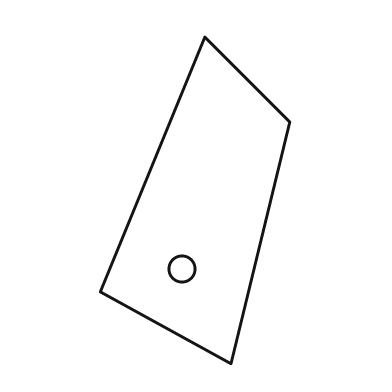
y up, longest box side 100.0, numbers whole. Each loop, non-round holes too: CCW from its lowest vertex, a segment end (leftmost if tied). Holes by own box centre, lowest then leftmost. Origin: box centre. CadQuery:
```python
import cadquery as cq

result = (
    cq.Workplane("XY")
    .moveTo(11.0, -50.0)
    .lineTo(29.0, 24.0)
    .lineTo(3.0, 50.0)
    .lineTo(-29.0, -28.0)
    .close()
    .moveTo(-4.0, -21.0)
    .circle(4.0)
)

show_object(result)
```